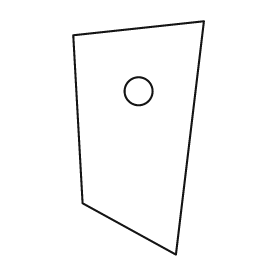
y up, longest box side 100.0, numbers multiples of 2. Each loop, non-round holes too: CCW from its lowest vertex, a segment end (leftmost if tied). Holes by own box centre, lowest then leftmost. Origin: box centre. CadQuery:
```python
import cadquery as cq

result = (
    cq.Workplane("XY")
    .moveTo(16.0, -50.0)
    .lineTo(28.0, 50.0)
    .lineTo(-28.0, 44.0)
    .lineTo(-24.0, -28.0)
    .close()
    .moveTo(0.0, 20.0)
    .circle(6.0)
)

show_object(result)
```